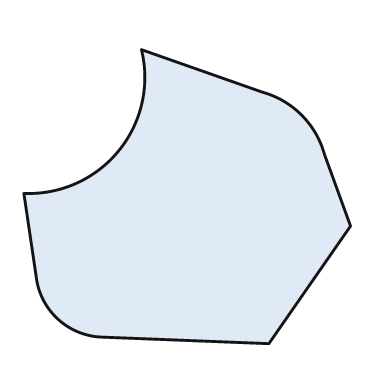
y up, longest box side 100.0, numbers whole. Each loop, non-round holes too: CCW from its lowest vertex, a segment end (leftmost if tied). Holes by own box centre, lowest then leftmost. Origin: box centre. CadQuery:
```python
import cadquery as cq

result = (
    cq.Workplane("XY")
    .moveTo(25.0, -45.0)
    .lineTo(50.0, -9.0)
    .lineTo(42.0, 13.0)
    .threePointArc((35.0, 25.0), (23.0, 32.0))
    .lineTo(-14.0, 45.0)
    .threePointArc((-21.0, 14.0), (-50.0, 1.0))
    .lineTo(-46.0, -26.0)
    .threePointArc((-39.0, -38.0), (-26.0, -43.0))
    .close()
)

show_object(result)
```